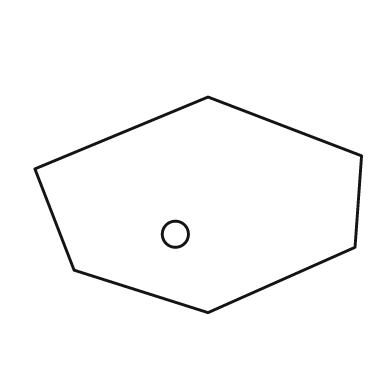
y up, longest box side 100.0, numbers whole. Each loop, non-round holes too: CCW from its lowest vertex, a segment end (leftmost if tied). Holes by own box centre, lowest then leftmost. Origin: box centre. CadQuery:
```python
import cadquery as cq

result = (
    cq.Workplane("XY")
    .moveTo(3.0, -33.0)
    .lineTo(48.0, -13.0)
    .lineTo(50.0, 15.0)
    .lineTo(3.0, 33.0)
    .lineTo(-50.0, 11.0)
    .lineTo(-38.0, -20.0)
    .close()
    .moveTo(-7.0, -9.0)
    .circle(4.0)
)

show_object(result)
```